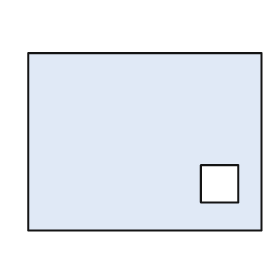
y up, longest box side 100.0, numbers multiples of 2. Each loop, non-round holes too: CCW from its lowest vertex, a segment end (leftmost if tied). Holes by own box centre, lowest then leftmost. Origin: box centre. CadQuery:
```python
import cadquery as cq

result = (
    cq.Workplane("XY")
    .moveTo(-50.0, -38.0)
    .lineTo(50.0, -38.0)
    .lineTo(50.0, 38.0)
    .lineTo(-50.0, 38.0)
    .close()
    .moveTo(24.0, -26.0)
    .lineTo(40.0, -26.0)
    .lineTo(40.0, -10.0)
    .lineTo(24.0, -10.0)
    .close()
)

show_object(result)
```